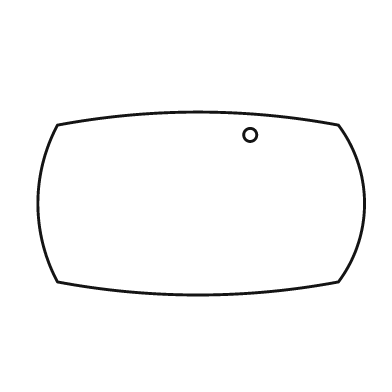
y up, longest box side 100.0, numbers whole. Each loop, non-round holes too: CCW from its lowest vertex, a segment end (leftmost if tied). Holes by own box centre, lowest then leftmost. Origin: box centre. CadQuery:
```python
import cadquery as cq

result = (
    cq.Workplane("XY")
    .moveTo(-44.0, -24.0)
    .threePointArc((-1.0, -28.0), (42.0, -24.0))
    .threePointArc((50.0, 0.0), (42.0, 24.0))
    .threePointArc((-1.0, 28.0), (-44.0, 24.0))
    .threePointArc((-50.0, 0.0), (-44.0, -24.0))
    .close()
    .moveTo(15.0, 21.0)
    .circle(2.0)
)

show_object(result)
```